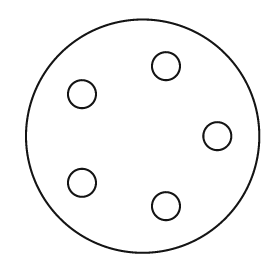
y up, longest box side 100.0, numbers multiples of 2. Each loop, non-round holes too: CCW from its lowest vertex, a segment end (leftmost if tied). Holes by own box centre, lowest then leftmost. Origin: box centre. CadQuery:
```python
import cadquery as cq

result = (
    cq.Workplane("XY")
    .moveTo(0.0, 0.0)
    .circle(50.0)
    .moveTo(10.0, -30.0)
    .circle(6.0)
    .moveTo(-26.0, -20.0)
    .circle(6.0)
    .moveTo(32.0, 0.0)
    .circle(6.0)
    .moveTo(-26.0, 18.0)
    .circle(6.0)
    .moveTo(10.0, 30.0)
    .circle(6.0)
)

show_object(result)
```